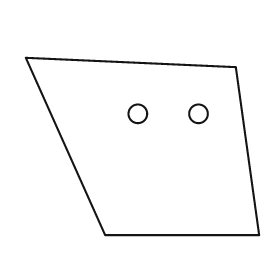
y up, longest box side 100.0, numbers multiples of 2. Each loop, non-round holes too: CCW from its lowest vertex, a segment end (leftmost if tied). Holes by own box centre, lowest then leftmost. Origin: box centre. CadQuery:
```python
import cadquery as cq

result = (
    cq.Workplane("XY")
    .moveTo(-16.0, -38.0)
    .lineTo(50.0, -38.0)
    .lineTo(40.0, 34.0)
    .lineTo(-50.0, 38.0)
    .close()
    .moveTo(-2.0, 14.0)
    .circle(4.0)
    .moveTo(24.0, 14.0)
    .circle(4.0)
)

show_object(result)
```